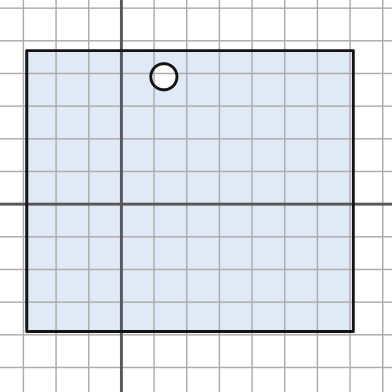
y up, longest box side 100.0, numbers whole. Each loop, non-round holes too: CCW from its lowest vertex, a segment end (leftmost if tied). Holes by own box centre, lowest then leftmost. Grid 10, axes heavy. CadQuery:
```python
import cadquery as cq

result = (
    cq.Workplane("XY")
    .moveTo(-29.0, -39.0)
    .lineTo(71.0, -39.0)
    .lineTo(71.0, 47.0)
    .lineTo(-29.0, 47.0)
    .close()
    .moveTo(13.0, 39.0)
    .circle(4.0)
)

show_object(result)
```